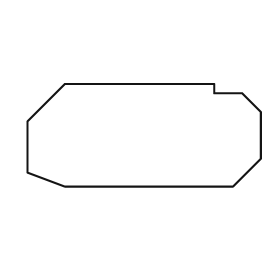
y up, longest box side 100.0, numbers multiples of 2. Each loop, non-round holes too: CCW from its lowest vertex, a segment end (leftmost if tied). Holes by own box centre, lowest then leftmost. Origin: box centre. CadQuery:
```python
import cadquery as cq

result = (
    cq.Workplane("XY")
    .moveTo(-34.0, -22.0)
    .lineTo(38.0, -22.0)
    .lineTo(50.0, -10.0)
    .lineTo(50.0, 10.0)
    .lineTo(42.0, 18.0)
    .lineTo(30.0, 18.0)
    .lineTo(30.0, 22.0)
    .lineTo(-34.0, 22.0)
    .lineTo(-50.0, 6.0)
    .lineTo(-50.0, -16.0)
    .close()
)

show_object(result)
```